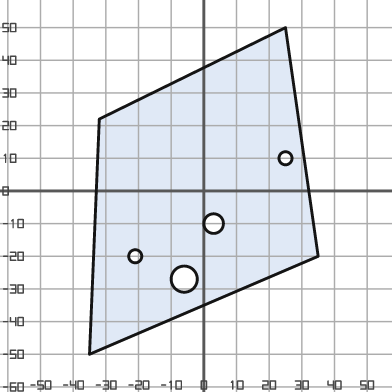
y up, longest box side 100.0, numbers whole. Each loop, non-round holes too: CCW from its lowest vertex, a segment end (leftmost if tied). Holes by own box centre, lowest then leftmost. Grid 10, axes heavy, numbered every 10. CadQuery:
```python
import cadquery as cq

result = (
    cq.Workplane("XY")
    .moveTo(-35.0, -50.0)
    .lineTo(35.0, -20.0)
    .lineTo(25.0, 50.0)
    .lineTo(-32.0, 22.0)
    .close()
    .moveTo(-6.0, -27.0)
    .circle(4.0)
    .moveTo(-21.0, -20.0)
    .circle(2.0)
    .moveTo(3.0, -10.0)
    .circle(3.0)
    .moveTo(25.0, 10.0)
    .circle(2.0)
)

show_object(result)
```